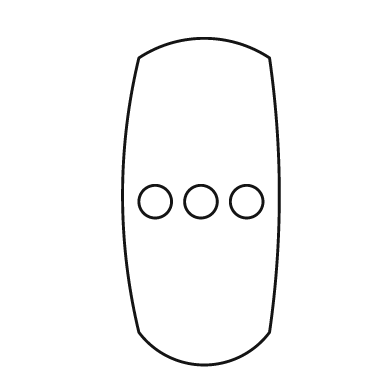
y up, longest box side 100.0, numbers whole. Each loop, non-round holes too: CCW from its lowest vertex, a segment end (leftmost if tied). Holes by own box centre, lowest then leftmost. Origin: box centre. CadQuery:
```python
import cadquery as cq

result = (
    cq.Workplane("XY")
    .moveTo(-19.0, -40.0)
    .threePointArc((1.0, -50.0), (21.0, -40.0))
    .threePointArc((24.0, 2.0), (21.0, 44.0))
    .threePointArc((1.0, 50.0), (-19.0, 44.0))
    .threePointArc((-24.0, 2.0), (-19.0, -40.0))
    .close()
    .moveTo(-14.0, 0.0)
    .circle(5.0)
    .moveTo(0.0, 0.0)
    .circle(5.0)
    .moveTo(14.0, 0.0)
    .circle(5.0)
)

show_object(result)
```